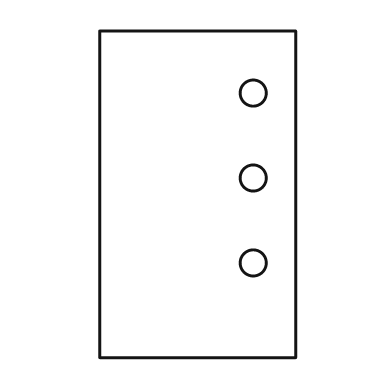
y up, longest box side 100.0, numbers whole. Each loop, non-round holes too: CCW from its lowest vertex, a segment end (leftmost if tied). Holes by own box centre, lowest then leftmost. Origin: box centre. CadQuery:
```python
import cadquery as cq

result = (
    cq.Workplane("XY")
    .moveTo(-30.0, -50.0)
    .lineTo(30.0, -50.0)
    .lineTo(30.0, 50.0)
    .lineTo(-30.0, 50.0)
    .close()
    .moveTo(17.0, -21.0)
    .circle(4.0)
    .moveTo(17.0, 5.0)
    .circle(4.0)
    .moveTo(17.0, 31.0)
    .circle(4.0)
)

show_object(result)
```